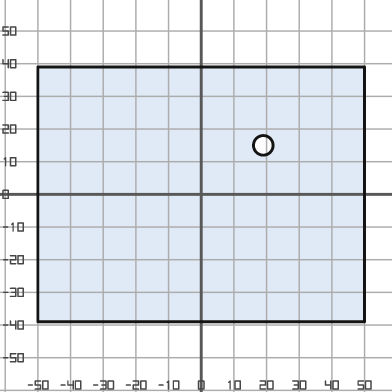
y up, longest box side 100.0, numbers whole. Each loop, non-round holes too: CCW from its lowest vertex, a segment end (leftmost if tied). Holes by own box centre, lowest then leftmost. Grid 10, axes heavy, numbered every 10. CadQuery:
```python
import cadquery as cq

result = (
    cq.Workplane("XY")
    .moveTo(-50.0, -39.0)
    .lineTo(50.0, -39.0)
    .lineTo(50.0, 39.0)
    .lineTo(-50.0, 39.0)
    .close()
    .moveTo(19.0, 15.0)
    .circle(3.0)
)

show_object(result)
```